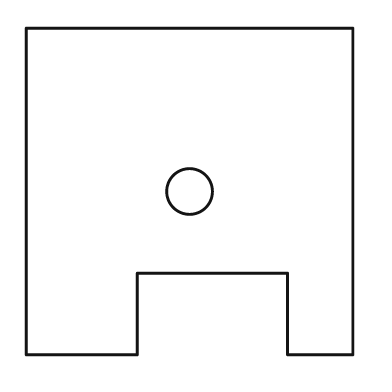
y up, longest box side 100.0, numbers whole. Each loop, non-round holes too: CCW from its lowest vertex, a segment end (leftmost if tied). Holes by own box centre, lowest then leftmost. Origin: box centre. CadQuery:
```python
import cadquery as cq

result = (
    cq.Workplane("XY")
    .moveTo(-50.0, -50.0)
    .lineTo(-16.0, -50.0)
    .lineTo(-16.0, -25.0)
    .lineTo(30.0, -25.0)
    .lineTo(30.0, -50.0)
    .lineTo(50.0, -50.0)
    .lineTo(50.0, 50.0)
    .lineTo(-50.0, 50.0)
    .close()
    .moveTo(0.0, 0.0)
    .circle(7.0)
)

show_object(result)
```